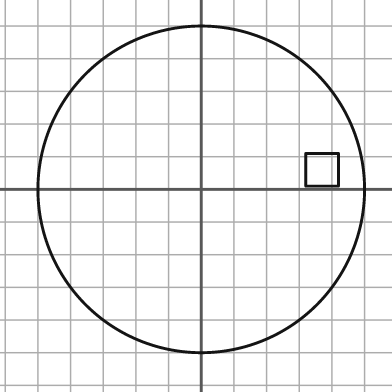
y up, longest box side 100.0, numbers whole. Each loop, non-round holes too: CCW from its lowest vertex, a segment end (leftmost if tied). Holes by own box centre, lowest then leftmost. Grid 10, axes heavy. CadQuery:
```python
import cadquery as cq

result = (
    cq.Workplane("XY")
    .moveTo(0.0, 0.0)
    .circle(50.0)
    .moveTo(32.0, 1.0)
    .lineTo(42.0, 1.0)
    .lineTo(42.0, 11.0)
    .lineTo(32.0, 11.0)
    .close()
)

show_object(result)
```